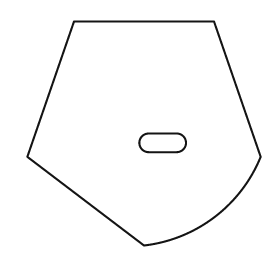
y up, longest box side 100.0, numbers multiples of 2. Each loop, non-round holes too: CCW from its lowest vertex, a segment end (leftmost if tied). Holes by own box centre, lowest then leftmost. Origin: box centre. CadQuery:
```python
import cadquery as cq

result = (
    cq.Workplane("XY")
    .moveTo(0.0, -48.0)
    .threePointArc((30.0, -36.0), (50.0, -10.0))
    .lineTo(30.0, 48.0)
    .lineTo(-30.0, 48.0)
    .lineTo(-50.0, -10.0)
    .close()
    .moveTo(2.0, -8.0)
    .lineTo(14.0, -8.0)
    .threePointArc((18.0, -4.0), (14.0, 0.0))
    .lineTo(2.0, 0.0)
    .threePointArc((-2.0, -4.0), (2.0, -8.0))
    .close()
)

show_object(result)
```